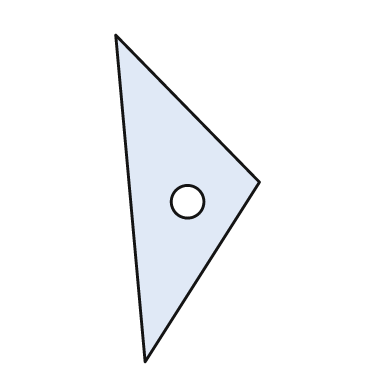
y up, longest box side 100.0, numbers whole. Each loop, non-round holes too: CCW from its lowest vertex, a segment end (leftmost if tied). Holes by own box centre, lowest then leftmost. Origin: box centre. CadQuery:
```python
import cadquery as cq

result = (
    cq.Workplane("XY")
    .moveTo(-13.0, -50.0)
    .lineTo(22.0, 5.0)
    .lineTo(-22.0, 50.0)
    .close()
    .moveTo(0.0, -1.0)
    .circle(5.0)
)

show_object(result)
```